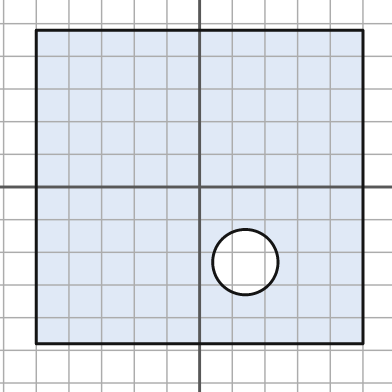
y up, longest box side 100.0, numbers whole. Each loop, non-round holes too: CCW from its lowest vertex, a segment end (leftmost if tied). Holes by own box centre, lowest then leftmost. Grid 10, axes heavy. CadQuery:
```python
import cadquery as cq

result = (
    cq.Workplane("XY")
    .moveTo(-50.0, -48.0)
    .lineTo(50.0, -48.0)
    .lineTo(50.0, 48.0)
    .lineTo(-50.0, 48.0)
    .close()
    .moveTo(14.0, -23.0)
    .circle(10.0)
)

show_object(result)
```